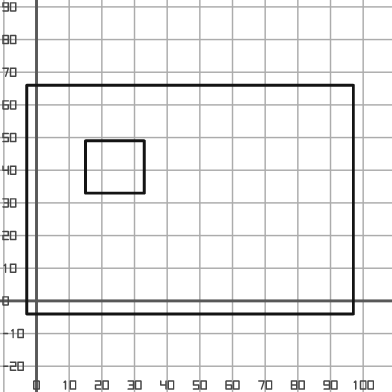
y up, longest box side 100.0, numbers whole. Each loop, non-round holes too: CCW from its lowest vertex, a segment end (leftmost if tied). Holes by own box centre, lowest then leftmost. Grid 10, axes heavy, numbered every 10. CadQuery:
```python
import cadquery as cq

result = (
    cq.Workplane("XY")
    .moveTo(-3.0, -4.0)
    .lineTo(97.0, -4.0)
    .lineTo(97.0, 66.0)
    .lineTo(-3.0, 66.0)
    .close()
    .moveTo(15.0, 33.0)
    .lineTo(33.0, 33.0)
    .lineTo(33.0, 49.0)
    .lineTo(15.0, 49.0)
    .close()
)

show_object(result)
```